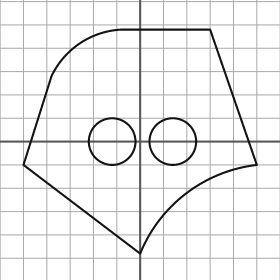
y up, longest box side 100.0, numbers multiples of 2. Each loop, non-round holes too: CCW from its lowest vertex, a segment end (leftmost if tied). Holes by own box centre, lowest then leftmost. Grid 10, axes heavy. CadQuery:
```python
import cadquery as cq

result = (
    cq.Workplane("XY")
    .moveTo(0.0, -48.0)
    .threePointArc((20.0, -22.0), (50.0, -10.0))
    .lineTo(30.0, 48.0)
    .lineTo(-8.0, 48.0)
    .threePointArc((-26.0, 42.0), (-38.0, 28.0))
    .lineTo(-50.0, -10.0)
    .close()
    .moveTo(-12.0, 0.0)
    .circle(10.0)
    .moveTo(14.0, 0.0)
    .circle(10.0)
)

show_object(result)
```